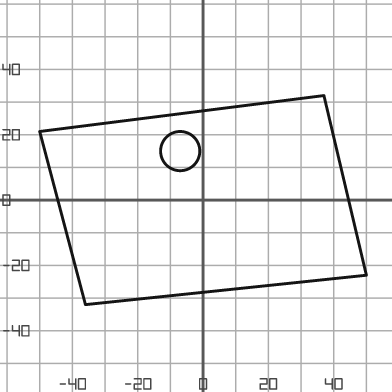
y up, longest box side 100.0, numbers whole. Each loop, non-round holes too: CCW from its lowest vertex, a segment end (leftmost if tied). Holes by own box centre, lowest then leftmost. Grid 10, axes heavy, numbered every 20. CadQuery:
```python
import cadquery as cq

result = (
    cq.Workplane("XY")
    .moveTo(-36.0, -32.0)
    .lineTo(50.0, -23.0)
    .lineTo(37.0, 32.0)
    .lineTo(-50.0, 21.0)
    .close()
    .moveTo(-7.0, 15.0)
    .circle(6.0)
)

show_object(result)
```